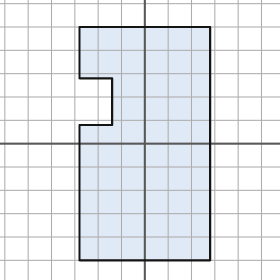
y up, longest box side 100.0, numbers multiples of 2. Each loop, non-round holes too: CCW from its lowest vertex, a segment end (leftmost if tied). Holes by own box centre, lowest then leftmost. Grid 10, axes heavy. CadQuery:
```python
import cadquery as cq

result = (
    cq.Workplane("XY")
    .moveTo(-28.0, -50.0)
    .lineTo(28.0, -50.0)
    .lineTo(28.0, 50.0)
    .lineTo(-28.0, 50.0)
    .lineTo(-28.0, 28.0)
    .lineTo(-14.0, 28.0)
    .lineTo(-14.0, 8.0)
    .lineTo(-28.0, 8.0)
    .close()
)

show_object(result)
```